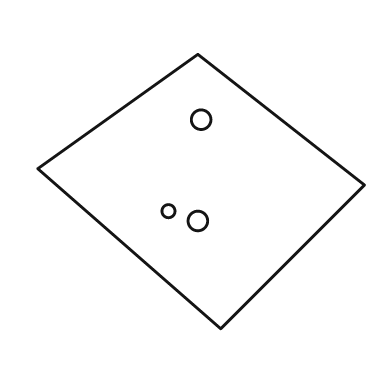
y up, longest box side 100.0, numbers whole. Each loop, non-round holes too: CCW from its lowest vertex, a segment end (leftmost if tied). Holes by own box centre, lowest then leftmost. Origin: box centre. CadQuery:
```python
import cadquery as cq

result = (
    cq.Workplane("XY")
    .moveTo(6.0, -42.0)
    .lineTo(50.0, 2.0)
    .lineTo(-1.0, 42.0)
    .lineTo(-50.0, 7.0)
    .close()
    .moveTo(-1.0, -9.0)
    .circle(3.0)
    .moveTo(-10.0, -6.0)
    .circle(2.0)
    .moveTo(0.0, 22.0)
    .circle(3.0)
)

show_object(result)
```